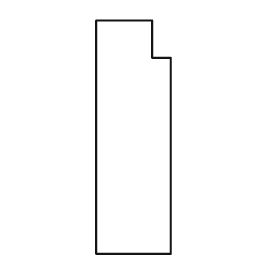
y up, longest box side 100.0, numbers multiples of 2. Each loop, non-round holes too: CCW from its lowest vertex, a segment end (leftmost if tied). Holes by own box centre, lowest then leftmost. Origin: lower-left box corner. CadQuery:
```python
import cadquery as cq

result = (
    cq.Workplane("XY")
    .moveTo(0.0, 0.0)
    .lineTo(32.0, 0.0)
    .lineTo(32.0, 84.0)
    .lineTo(24.0, 84.0)
    .lineTo(24.0, 100.0)
    .lineTo(0.0, 100.0)
    .close()
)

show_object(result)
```